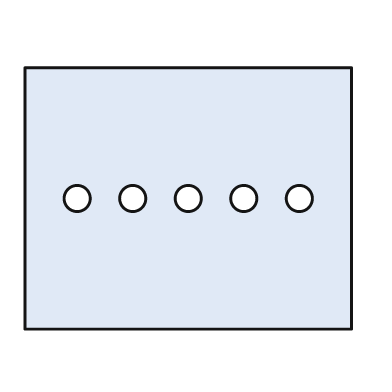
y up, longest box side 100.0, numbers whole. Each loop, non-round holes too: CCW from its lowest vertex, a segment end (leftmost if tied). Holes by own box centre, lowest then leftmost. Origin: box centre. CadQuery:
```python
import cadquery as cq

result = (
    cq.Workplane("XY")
    .moveTo(-50.0, -40.0)
    .lineTo(50.0, -40.0)
    .lineTo(50.0, 40.0)
    .lineTo(-50.0, 40.0)
    .close()
    .moveTo(-34.0, 0.0)
    .circle(4.0)
    .moveTo(-17.0, 0.0)
    .circle(4.0)
    .moveTo(0.0, 0.0)
    .circle(4.0)
    .moveTo(17.0, 0.0)
    .circle(4.0)
    .moveTo(34.0, 0.0)
    .circle(4.0)
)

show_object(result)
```